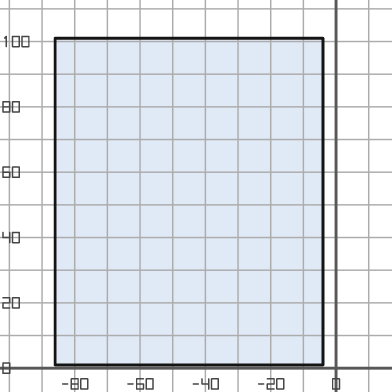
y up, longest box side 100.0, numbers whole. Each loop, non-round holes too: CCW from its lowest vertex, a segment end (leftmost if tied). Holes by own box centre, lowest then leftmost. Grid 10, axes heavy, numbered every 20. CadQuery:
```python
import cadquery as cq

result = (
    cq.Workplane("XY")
    .moveTo(-86.0, 1.0)
    .lineTo(-4.0, 1.0)
    .lineTo(-4.0, 101.0)
    .lineTo(-86.0, 101.0)
    .close()
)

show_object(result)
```